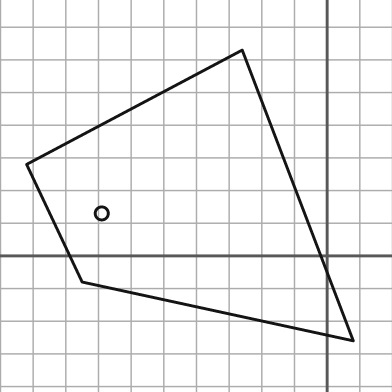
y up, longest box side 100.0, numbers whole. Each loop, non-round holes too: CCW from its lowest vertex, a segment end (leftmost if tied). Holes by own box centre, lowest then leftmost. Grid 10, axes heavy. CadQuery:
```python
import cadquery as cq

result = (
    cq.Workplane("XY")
    .moveTo(8.0, -26.0)
    .lineTo(-26.0, 63.0)
    .lineTo(-92.0, 28.0)
    .lineTo(-75.0, -8.0)
    .close()
    .moveTo(-69.0, 13.0)
    .circle(2.0)
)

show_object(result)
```